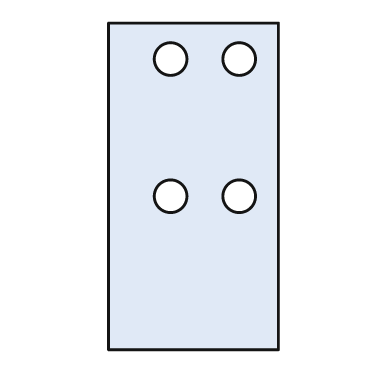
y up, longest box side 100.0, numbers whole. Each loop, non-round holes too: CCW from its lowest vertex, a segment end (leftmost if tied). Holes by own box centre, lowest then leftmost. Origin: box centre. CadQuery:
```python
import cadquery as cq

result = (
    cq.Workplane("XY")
    .moveTo(-26.0, -50.0)
    .lineTo(26.0, -50.0)
    .lineTo(26.0, 50.0)
    .lineTo(-26.0, 50.0)
    .close()
    .moveTo(-7.0, -3.0)
    .circle(5.0)
    .moveTo(14.0, -3.0)
    .circle(5.0)
    .moveTo(-7.0, 39.0)
    .circle(5.0)
    .moveTo(14.0, 39.0)
    .circle(5.0)
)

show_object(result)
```